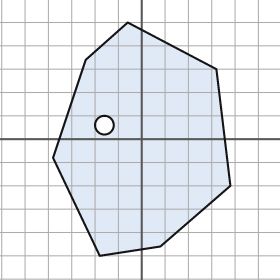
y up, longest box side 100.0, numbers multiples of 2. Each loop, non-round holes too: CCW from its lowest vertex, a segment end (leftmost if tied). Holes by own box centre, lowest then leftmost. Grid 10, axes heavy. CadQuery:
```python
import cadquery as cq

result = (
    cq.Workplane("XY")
    .moveTo(-18.0, -50.0)
    .lineTo(8.0, -46.0)
    .lineTo(38.0, -20.0)
    .lineTo(32.0, 30.0)
    .lineTo(-6.0, 50.0)
    .lineTo(-24.0, 34.0)
    .lineTo(-38.0, -8.0)
    .close()
    .moveTo(-16.0, 6.0)
    .circle(4.0)
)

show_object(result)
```